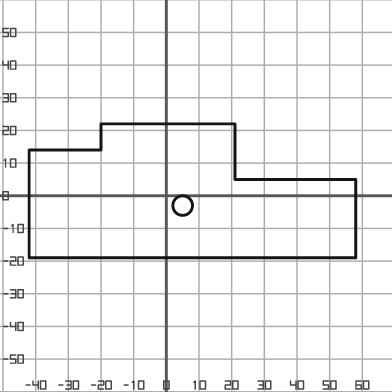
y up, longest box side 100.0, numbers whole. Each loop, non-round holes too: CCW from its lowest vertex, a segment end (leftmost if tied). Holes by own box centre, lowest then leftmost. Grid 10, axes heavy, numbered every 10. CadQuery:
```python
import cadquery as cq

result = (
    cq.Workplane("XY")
    .moveTo(-42.0, -19.0)
    .lineTo(58.0, -19.0)
    .lineTo(58.0, 5.0)
    .lineTo(21.0, 5.0)
    .lineTo(21.0, 22.0)
    .lineTo(-20.0, 22.0)
    .lineTo(-20.0, 14.0)
    .lineTo(-42.0, 14.0)
    .close()
    .moveTo(5.0, -3.0)
    .circle(3.0)
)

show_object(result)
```